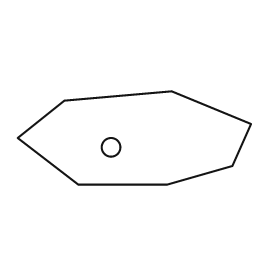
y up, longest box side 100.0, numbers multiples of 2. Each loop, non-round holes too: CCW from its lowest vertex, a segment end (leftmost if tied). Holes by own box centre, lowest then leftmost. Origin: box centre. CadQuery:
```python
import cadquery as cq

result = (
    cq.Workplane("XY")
    .moveTo(-24.0, -20.0)
    .lineTo(14.0, -20.0)
    .lineTo(42.0, -12.0)
    .lineTo(50.0, 6.0)
    .lineTo(16.0, 20.0)
    .lineTo(-30.0, 16.0)
    .lineTo(-50.0, 0.0)
    .close()
    .moveTo(-10.0, -4.0)
    .circle(4.0)
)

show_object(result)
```